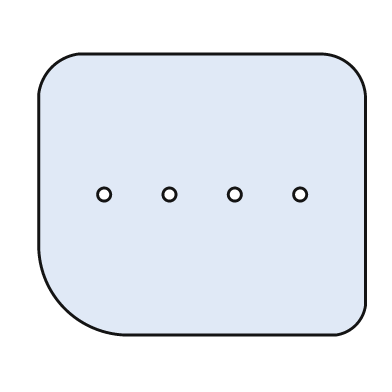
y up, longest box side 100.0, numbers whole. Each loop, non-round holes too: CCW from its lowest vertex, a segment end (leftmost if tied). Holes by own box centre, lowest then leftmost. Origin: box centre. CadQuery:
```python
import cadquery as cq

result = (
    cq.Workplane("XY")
    .moveTo(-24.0, -43.0)
    .lineTo(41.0, -43.0)
    .threePointArc((47.0, -40.0), (50.0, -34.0))
    .lineTo(50.0, 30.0)
    .threePointArc((46.0, 39.0), (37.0, 43.0))
    .lineTo(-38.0, 43.0)
    .threePointArc((-46.0, 39.0), (-50.0, 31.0))
    .lineTo(-50.0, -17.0)
    .threePointArc((-42.0, -35.0), (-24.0, -43.0))
    .close()
    .moveTo(-30.0, 0.0)
    .circle(2.0)
    .moveTo(-10.0, 0.0)
    .circle(2.0)
    .moveTo(10.0, 0.0)
    .circle(2.0)
    .moveTo(30.0, 0.0)
    .circle(2.0)
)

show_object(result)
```